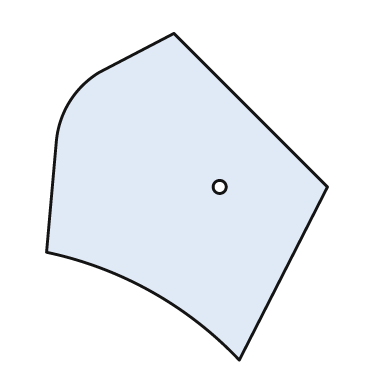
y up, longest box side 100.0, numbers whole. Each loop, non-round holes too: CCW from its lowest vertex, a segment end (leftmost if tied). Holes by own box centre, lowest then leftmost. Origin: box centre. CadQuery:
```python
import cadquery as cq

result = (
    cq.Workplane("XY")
    .moveTo(16.0, -50.0)
    .lineTo(43.0, 3.0)
    .lineTo(-4.0, 50.0)
    .lineTo(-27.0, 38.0)
    .threePointArc((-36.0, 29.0), (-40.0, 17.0))
    .lineTo(-43.0, -17.0)
    .threePointArc((-11.0, -29.0), (16.0, -50.0))
    .close()
    .moveTo(10.0, 3.0)
    .circle(2.0)
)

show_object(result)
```